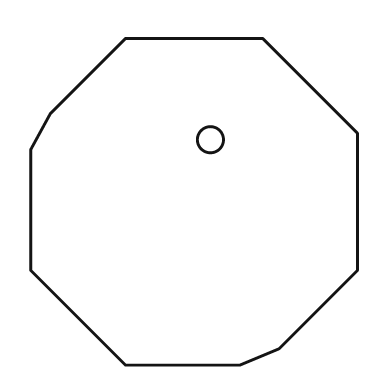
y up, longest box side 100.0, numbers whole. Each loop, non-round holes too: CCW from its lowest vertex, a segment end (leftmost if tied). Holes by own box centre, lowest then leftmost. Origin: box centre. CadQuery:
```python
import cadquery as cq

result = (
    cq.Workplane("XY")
    .moveTo(-21.0, -50.0)
    .lineTo(14.0, -50.0)
    .lineTo(26.0, -45.0)
    .lineTo(50.0, -21.0)
    .lineTo(50.0, 21.0)
    .lineTo(21.0, 50.0)
    .lineTo(-21.0, 50.0)
    .lineTo(-44.0, 27.0)
    .lineTo(-50.0, 16.0)
    .lineTo(-50.0, -21.0)
    .close()
    .moveTo(5.0, 19.0)
    .circle(4.0)
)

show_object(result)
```